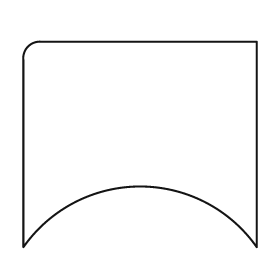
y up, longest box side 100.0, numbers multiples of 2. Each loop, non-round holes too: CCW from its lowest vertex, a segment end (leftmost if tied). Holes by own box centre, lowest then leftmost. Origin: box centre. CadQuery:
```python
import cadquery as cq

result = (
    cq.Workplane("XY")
    .moveTo(-50.0, -44.0)
    .threePointArc((0.0, -18.0), (50.0, -44.0))
    .lineTo(50.0, 44.0)
    .lineTo(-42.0, 44.0)
    .threePointArc((-48.0, 42.0), (-50.0, 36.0))
    .close()
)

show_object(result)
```